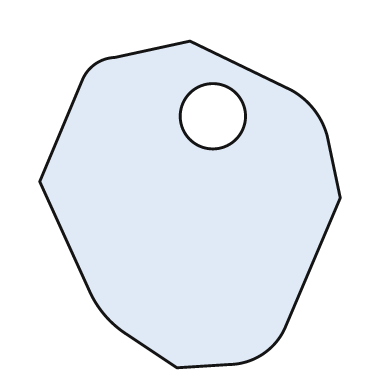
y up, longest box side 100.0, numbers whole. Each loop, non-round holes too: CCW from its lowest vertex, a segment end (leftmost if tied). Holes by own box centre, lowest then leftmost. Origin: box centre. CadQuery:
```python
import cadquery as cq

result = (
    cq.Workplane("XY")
    .moveTo(-4.0, -50.0)
    .lineTo(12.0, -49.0)
    .threePointArc((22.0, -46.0), (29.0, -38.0))
    .lineTo(46.0, 2.0)
    .lineTo(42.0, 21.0)
    .threePointArc((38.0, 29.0), (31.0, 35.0))
    .lineTo(0.0, 50.0)
    .lineTo(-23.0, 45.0)
    .threePointArc((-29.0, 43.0), (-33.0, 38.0))
    .lineTo(-46.0, 7.0)
    .lineTo(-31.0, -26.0)
    .threePointArc((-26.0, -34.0), (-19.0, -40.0))
    .close()
    .moveTo(7.0, 27.0)
    .circle(10.0)
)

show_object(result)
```